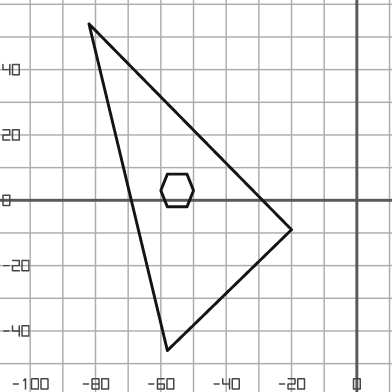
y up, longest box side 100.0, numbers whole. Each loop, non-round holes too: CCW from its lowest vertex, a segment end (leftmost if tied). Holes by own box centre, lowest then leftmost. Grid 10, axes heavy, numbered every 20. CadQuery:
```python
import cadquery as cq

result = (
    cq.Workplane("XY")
    .moveTo(-58.0, -46.0)
    .lineTo(-20.0, -9.0)
    .lineTo(-82.0, 54.0)
    .close()
    .moveTo(-58.0, -2.0)
    .lineTo(-52.0, -2.0)
    .lineTo(-50.0, 3.0)
    .lineTo(-52.0, 8.0)
    .lineTo(-58.0, 8.0)
    .lineTo(-60.0, 3.0)
    .close()
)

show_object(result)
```